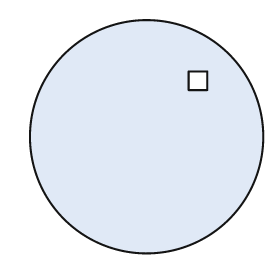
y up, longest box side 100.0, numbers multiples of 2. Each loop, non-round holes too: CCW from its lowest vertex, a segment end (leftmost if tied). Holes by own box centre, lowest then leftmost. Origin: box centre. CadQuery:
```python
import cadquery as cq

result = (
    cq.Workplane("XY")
    .moveTo(0.0, 0.0)
    .circle(50.0)
    .moveTo(18.0, 20.0)
    .lineTo(26.0, 20.0)
    .lineTo(26.0, 28.0)
    .lineTo(18.0, 28.0)
    .close()
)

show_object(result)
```